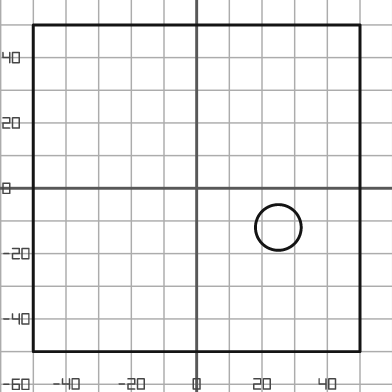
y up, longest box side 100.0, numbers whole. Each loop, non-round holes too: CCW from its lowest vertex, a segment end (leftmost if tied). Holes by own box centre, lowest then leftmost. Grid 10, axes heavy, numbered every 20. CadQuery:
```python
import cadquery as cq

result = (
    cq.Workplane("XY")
    .moveTo(-50.0, -50.0)
    .lineTo(50.0, -50.0)
    .lineTo(50.0, 50.0)
    .lineTo(-50.0, 50.0)
    .close()
    .moveTo(25.0, -12.0)
    .circle(7.0)
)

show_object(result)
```